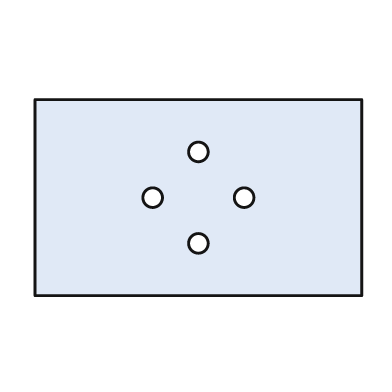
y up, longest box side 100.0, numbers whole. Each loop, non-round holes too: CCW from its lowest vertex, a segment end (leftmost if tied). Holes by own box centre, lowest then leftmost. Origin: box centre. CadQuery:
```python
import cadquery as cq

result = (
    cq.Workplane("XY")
    .moveTo(-50.0, -30.0)
    .lineTo(50.0, -30.0)
    .lineTo(50.0, 30.0)
    .lineTo(-50.0, 30.0)
    .close()
    .moveTo(0.0, -14.0)
    .circle(3.0)
    .moveTo(-14.0, 0.0)
    .circle(3.0)
    .moveTo(14.0, 0.0)
    .circle(3.0)
    .moveTo(0.0, 14.0)
    .circle(3.0)
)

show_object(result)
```